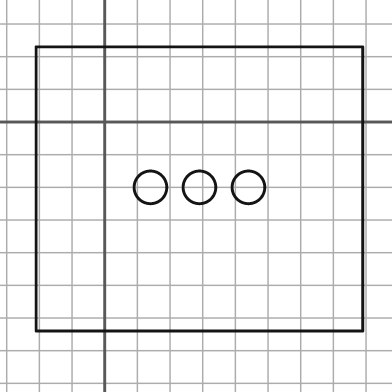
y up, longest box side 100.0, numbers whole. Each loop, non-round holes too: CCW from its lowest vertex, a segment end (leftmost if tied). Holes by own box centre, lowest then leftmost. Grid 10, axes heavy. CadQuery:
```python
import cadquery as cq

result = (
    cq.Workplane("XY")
    .moveTo(-21.0, -64.0)
    .lineTo(79.0, -64.0)
    .lineTo(79.0, 23.0)
    .lineTo(-21.0, 23.0)
    .close()
    .moveTo(14.0, -20.0)
    .circle(5.0)
    .moveTo(29.0, -20.0)
    .circle(5.0)
    .moveTo(44.0, -20.0)
    .circle(5.0)
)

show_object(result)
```